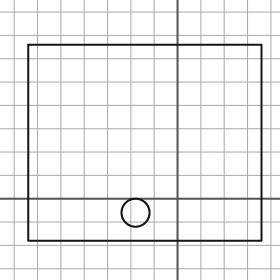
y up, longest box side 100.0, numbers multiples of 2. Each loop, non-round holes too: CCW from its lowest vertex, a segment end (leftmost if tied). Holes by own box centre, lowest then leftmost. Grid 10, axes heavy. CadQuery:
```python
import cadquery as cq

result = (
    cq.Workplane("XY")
    .moveTo(-64.0, -18.0)
    .lineTo(36.0, -18.0)
    .lineTo(36.0, 66.0)
    .lineTo(-64.0, 66.0)
    .close()
    .moveTo(-18.0, -6.0)
    .circle(6.0)
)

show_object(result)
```